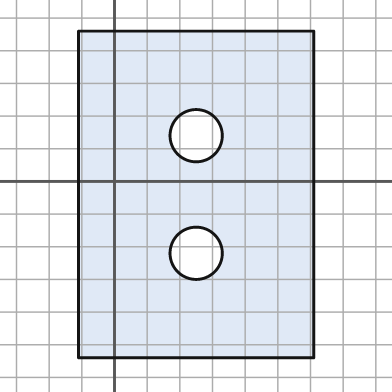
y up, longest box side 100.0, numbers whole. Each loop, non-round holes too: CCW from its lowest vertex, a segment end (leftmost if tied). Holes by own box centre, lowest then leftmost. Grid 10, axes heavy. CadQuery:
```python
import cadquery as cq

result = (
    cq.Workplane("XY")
    .moveTo(-11.0, -54.0)
    .lineTo(61.0, -54.0)
    .lineTo(61.0, 46.0)
    .lineTo(-11.0, 46.0)
    .close()
    .moveTo(25.0, -22.0)
    .circle(8.0)
    .moveTo(25.0, 14.0)
    .circle(8.0)
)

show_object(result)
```